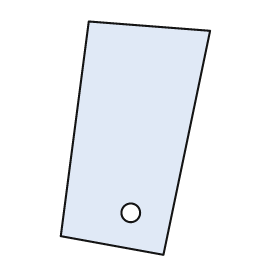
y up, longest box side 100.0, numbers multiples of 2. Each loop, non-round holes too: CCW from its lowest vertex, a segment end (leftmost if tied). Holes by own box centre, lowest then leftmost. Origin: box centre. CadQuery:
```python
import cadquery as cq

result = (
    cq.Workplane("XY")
    .moveTo(12.0, -50.0)
    .lineTo(32.0, 46.0)
    .lineTo(-20.0, 50.0)
    .lineTo(-32.0, -42.0)
    .close()
    .moveTo(-2.0, -32.0)
    .circle(4.0)
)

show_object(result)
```